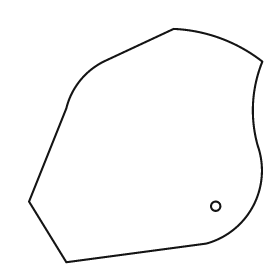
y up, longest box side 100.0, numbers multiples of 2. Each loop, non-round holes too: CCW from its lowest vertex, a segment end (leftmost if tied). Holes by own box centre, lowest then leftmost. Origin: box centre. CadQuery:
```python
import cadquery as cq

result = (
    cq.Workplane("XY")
    .moveTo(-34.0, -50.0)
    .lineTo(26.0, -42.0)
    .threePointArc((46.0, -26.0), (48.0, 0.0))
    .threePointArc((46.0, 18.0), (50.0, 36.0))
    .threePointArc((32.0, 46.0), (12.0, 50.0))
    .lineTo(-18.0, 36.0)
    .threePointArc((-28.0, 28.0), (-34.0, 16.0))
    .lineTo(-50.0, -24.0)
    .close()
    .moveTo(30.0, -26.0)
    .circle(2.0)
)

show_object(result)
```